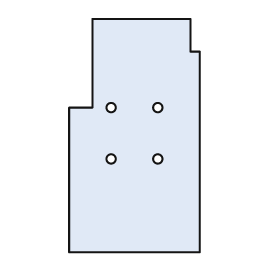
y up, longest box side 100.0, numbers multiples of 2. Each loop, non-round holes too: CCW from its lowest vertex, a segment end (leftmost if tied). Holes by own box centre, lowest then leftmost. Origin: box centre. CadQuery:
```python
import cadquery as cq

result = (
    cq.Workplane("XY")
    .moveTo(-28.0, -50.0)
    .lineTo(28.0, -50.0)
    .lineTo(28.0, 36.0)
    .lineTo(24.0, 36.0)
    .lineTo(24.0, 50.0)
    .lineTo(-18.0, 50.0)
    .lineTo(-18.0, 12.0)
    .lineTo(-28.0, 12.0)
    .close()
    .moveTo(-10.0, -10.0)
    .circle(2.0)
    .moveTo(10.0, -10.0)
    .circle(2.0)
    .moveTo(-10.0, 12.0)
    .circle(2.0)
    .moveTo(10.0, 12.0)
    .circle(2.0)
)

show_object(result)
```